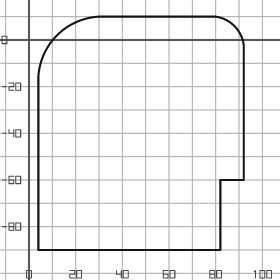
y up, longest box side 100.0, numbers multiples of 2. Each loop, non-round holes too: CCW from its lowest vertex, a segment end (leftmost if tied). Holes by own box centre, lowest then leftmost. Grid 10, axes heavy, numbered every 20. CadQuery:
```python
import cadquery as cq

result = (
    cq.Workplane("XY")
    .moveTo(4.0, -90.0)
    .lineTo(82.0, -90.0)
    .lineTo(82.0, -60.0)
    .lineTo(92.0, -60.0)
    .lineTo(92.0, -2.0)
    .threePointArc((88.0, 6.0), (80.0, 10.0))
    .lineTo(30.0, 10.0)
    .threePointArc((12.0, 2.0), (4.0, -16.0))
    .close()
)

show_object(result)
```